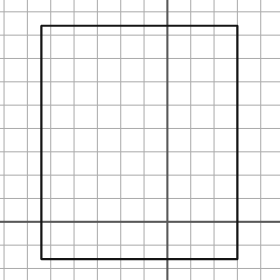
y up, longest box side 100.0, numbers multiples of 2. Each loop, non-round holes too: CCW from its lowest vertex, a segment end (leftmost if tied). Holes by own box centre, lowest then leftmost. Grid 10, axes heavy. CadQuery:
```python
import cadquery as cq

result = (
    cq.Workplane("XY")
    .moveTo(-54.0, -16.0)
    .lineTo(30.0, -16.0)
    .lineTo(30.0, 84.0)
    .lineTo(-54.0, 84.0)
    .close()
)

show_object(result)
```